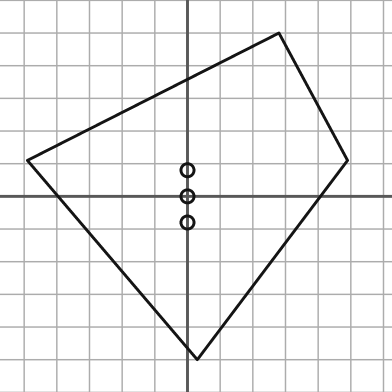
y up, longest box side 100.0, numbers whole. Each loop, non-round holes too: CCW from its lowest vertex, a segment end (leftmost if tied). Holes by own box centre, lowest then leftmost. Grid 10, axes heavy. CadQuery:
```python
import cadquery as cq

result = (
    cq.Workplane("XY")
    .moveTo(3.0, -50.0)
    .lineTo(49.0, 11.0)
    .lineTo(28.0, 50.0)
    .lineTo(-49.0, 11.0)
    .close()
    .moveTo(0.0, -8.0)
    .circle(2.0)
    .moveTo(0.0, 0.0)
    .circle(2.0)
    .moveTo(0.0, 8.0)
    .circle(2.0)
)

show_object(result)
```